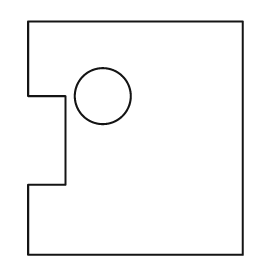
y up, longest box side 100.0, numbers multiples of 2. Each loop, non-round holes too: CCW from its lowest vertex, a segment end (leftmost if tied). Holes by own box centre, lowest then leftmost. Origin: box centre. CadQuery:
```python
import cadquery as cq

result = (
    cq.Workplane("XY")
    .moveTo(-46.0, -50.0)
    .lineTo(46.0, -50.0)
    .lineTo(46.0, 50.0)
    .lineTo(-46.0, 50.0)
    .lineTo(-46.0, 18.0)
    .lineTo(-30.0, 18.0)
    .lineTo(-30.0, -20.0)
    .lineTo(-46.0, -20.0)
    .close()
    .moveTo(-14.0, 18.0)
    .circle(12.0)
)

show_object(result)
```